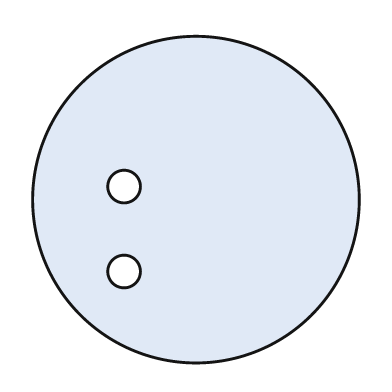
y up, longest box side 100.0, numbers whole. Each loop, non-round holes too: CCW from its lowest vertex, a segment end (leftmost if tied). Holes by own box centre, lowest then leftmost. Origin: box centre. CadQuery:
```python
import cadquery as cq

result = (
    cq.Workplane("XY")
    .moveTo(0.0, 0.0)
    .circle(50.0)
    .moveTo(-22.0, -22.0)
    .circle(5.0)
    .moveTo(-22.0, 4.0)
    .circle(5.0)
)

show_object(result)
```